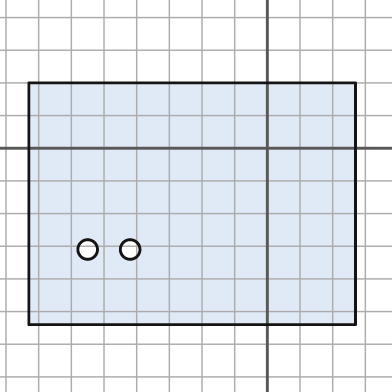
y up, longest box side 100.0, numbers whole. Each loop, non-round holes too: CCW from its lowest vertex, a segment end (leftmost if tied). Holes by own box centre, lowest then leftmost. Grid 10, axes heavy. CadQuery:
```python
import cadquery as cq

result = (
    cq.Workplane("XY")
    .moveTo(-73.0, -54.0)
    .lineTo(27.0, -54.0)
    .lineTo(27.0, 20.0)
    .lineTo(-73.0, 20.0)
    .close()
    .moveTo(-55.0, -31.0)
    .circle(3.0)
    .moveTo(-42.0, -31.0)
    .circle(3.0)
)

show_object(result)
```